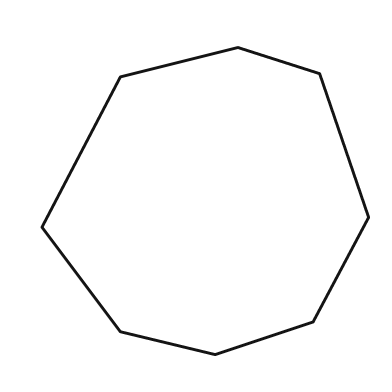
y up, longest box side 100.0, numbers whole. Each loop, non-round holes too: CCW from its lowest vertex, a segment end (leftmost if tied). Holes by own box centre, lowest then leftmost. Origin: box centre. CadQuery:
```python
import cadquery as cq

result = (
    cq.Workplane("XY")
    .moveTo(3.0, -47.0)
    .lineTo(33.0, -37.0)
    .lineTo(50.0, -5.0)
    .lineTo(35.0, 39.0)
    .lineTo(10.0, 47.0)
    .lineTo(-26.0, 38.0)
    .lineTo(-50.0, -8.0)
    .lineTo(-26.0, -40.0)
    .close()
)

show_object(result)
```